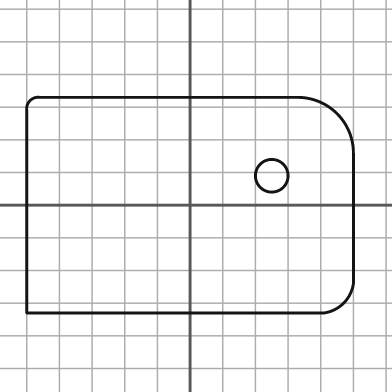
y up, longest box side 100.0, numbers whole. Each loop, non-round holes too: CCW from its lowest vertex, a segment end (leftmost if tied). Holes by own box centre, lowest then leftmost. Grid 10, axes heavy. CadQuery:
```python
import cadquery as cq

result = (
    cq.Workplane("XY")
    .moveTo(-50.0, -33.0)
    .lineTo(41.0, -33.0)
    .threePointArc((47.0, -30.0), (50.0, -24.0))
    .lineTo(50.0, 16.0)
    .threePointArc((45.0, 28.0), (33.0, 33.0))
    .lineTo(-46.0, 33.0)
    .threePointArc((-49.0, 32.0), (-50.0, 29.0))
    .close()
    .moveTo(25.0, 9.0)
    .circle(5.0)
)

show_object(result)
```